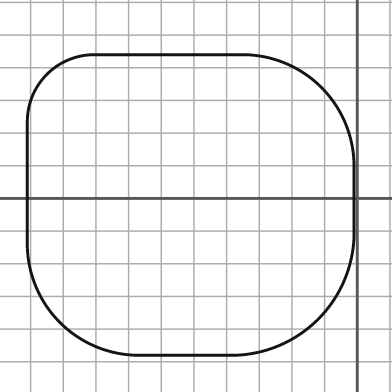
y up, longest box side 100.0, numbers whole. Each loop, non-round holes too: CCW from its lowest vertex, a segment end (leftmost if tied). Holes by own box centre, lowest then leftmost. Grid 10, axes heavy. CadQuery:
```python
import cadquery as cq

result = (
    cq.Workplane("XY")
    .moveTo(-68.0, -48.0)
    .lineTo(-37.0, -48.0)
    .threePointArc((-12.0, -37.0), (-1.0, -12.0))
    .lineTo(-1.0, 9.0)
    .threePointArc((-11.0, 34.0), (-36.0, 44.0))
    .lineTo(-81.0, 44.0)
    .threePointArc((-95.0, 38.0), (-101.0, 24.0))
    .lineTo(-101.0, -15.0)
    .threePointArc((-91.0, -38.0), (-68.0, -48.0))
    .close()
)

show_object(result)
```